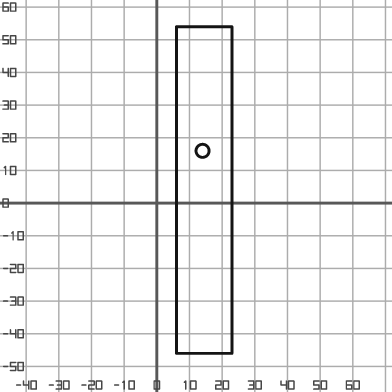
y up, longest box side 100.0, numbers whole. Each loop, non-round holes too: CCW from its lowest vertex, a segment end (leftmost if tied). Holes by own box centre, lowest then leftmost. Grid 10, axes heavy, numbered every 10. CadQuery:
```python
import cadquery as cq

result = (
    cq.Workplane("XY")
    .moveTo(6.0, -46.0)
    .lineTo(23.0, -46.0)
    .lineTo(23.0, 54.0)
    .lineTo(6.0, 54.0)
    .close()
    .moveTo(14.0, 16.0)
    .circle(2.0)
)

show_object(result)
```